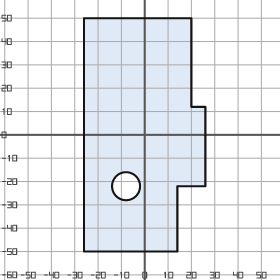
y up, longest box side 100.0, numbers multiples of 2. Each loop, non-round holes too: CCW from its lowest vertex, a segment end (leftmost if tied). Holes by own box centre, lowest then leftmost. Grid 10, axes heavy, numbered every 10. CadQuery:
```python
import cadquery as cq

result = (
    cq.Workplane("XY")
    .moveTo(-26.0, -50.0)
    .lineTo(14.0, -50.0)
    .lineTo(14.0, -22.0)
    .lineTo(26.0, -22.0)
    .lineTo(26.0, 12.0)
    .lineTo(20.0, 12.0)
    .lineTo(20.0, 50.0)
    .lineTo(-26.0, 50.0)
    .close()
    .moveTo(-8.0, -22.0)
    .circle(6.0)
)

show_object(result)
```